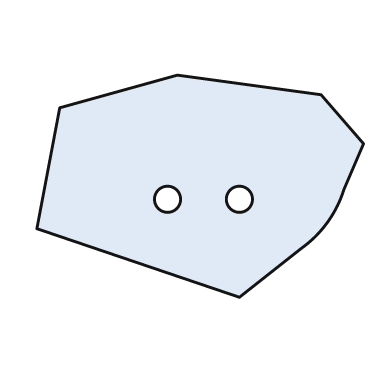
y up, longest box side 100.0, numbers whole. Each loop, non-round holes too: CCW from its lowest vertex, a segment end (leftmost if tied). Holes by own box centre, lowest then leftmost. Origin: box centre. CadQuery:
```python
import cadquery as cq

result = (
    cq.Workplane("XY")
    .moveTo(12.0, -34.0)
    .lineTo(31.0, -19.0)
    .threePointArc((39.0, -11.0), (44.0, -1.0))
    .lineTo(50.0, 13.0)
    .lineTo(37.0, 28.0)
    .lineTo(-7.0, 34.0)
    .lineTo(-43.0, 24.0)
    .lineTo(-50.0, -13.0)
    .close()
    .moveTo(-10.0, -4.0)
    .circle(4.0)
    .moveTo(12.0, -4.0)
    .circle(4.0)
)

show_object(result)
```